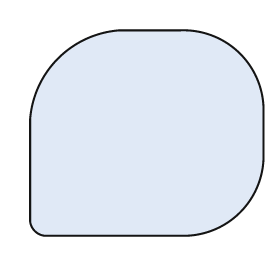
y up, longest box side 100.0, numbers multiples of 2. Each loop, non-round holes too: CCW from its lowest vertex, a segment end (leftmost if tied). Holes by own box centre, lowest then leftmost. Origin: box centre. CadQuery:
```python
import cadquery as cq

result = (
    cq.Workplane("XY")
    .moveTo(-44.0, -44.0)
    .lineTo(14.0, -44.0)
    .threePointArc((40.0, -34.0), (50.0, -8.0))
    .lineTo(50.0, 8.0)
    .threePointArc((40.0, 34.0), (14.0, 44.0))
    .lineTo(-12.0, 44.0)
    .threePointArc((-38.0, 32.0), (-50.0, 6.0))
    .lineTo(-50.0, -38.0)
    .threePointArc((-48.0, -42.0), (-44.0, -44.0))
    .close()
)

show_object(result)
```